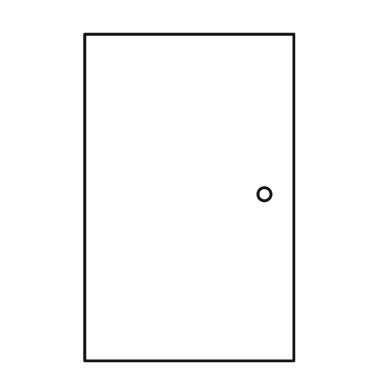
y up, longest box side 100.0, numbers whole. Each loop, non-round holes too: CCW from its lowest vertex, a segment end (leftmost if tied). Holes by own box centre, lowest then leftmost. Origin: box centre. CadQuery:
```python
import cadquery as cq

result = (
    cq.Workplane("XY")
    .moveTo(-32.0, -50.0)
    .lineTo(32.0, -50.0)
    .lineTo(32.0, 50.0)
    .lineTo(-32.0, 50.0)
    .close()
    .moveTo(23.0, 1.0)
    .circle(2.0)
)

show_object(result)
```